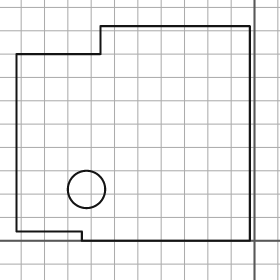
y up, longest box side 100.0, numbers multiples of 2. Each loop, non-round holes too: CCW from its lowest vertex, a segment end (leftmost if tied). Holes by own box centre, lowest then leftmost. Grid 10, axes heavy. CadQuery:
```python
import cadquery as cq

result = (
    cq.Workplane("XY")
    .moveTo(-74.0, 0.0)
    .lineTo(-2.0, 0.0)
    .lineTo(-2.0, 92.0)
    .lineTo(-66.0, 92.0)
    .lineTo(-66.0, 80.0)
    .lineTo(-102.0, 80.0)
    .lineTo(-102.0, 4.0)
    .lineTo(-74.0, 4.0)
    .close()
    .moveTo(-72.0, 22.0)
    .circle(8.0)
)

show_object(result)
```